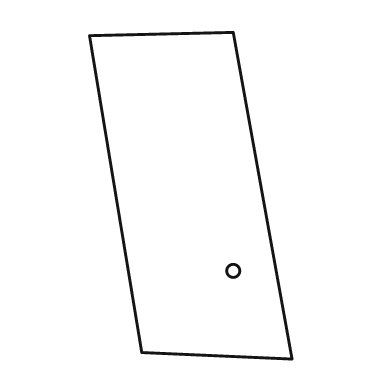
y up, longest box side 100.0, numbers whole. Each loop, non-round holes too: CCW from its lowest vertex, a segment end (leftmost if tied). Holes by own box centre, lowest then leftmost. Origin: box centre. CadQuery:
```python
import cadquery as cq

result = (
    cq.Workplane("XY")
    .moveTo(31.0, -50.0)
    .lineTo(13.0, 50.0)
    .lineTo(-31.0, 49.0)
    .lineTo(-15.0, -48.0)
    .close()
    .moveTo(13.0, -23.0)
    .circle(2.0)
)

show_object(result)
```